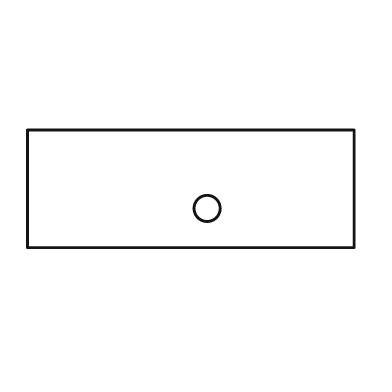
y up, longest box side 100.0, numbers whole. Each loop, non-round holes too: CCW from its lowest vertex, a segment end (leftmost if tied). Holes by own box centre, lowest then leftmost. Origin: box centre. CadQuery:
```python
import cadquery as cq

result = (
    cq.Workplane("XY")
    .moveTo(-50.0, -18.0)
    .lineTo(50.0, -18.0)
    .lineTo(50.0, 18.0)
    .lineTo(-50.0, 18.0)
    .close()
    .moveTo(5.0, -6.0)
    .circle(4.0)
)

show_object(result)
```